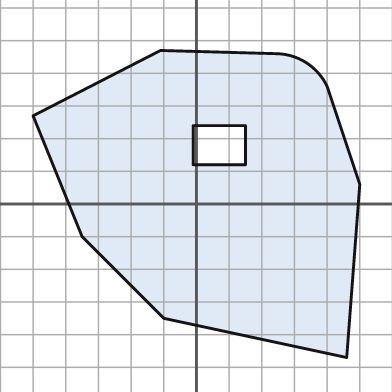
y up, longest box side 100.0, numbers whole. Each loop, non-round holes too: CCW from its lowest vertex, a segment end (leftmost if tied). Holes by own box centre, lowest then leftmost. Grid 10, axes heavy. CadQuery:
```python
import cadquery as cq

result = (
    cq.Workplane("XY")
    .moveTo(46.0, -47.0)
    .lineTo(50.0, 6.0)
    .lineTo(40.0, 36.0)
    .threePointArc((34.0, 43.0), (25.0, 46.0))
    .lineTo(-11.0, 47.0)
    .lineTo(-50.0, 27.0)
    .lineTo(-35.0, -10.0)
    .lineTo(-10.0, -35.0)
    .close()
    .moveTo(-1.0, 12.0)
    .lineTo(15.0, 12.0)
    .lineTo(15.0, 24.0)
    .lineTo(-1.0, 24.0)
    .close()
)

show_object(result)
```